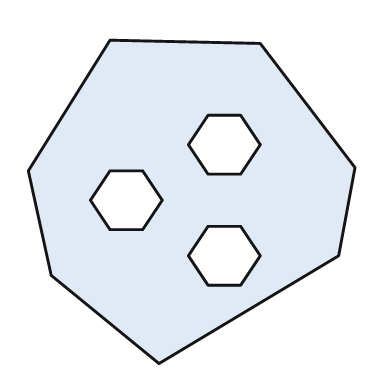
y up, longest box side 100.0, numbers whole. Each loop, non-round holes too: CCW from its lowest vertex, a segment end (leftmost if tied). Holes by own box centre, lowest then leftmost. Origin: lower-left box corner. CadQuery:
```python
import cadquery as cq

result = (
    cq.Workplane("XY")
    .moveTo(40.0, 0.0)
    .lineTo(95.0, 33.0)
    .lineTo(100.0, 60.0)
    .lineTo(71.0, 98.0)
    .lineTo(25.0, 99.0)
    .lineTo(0.0, 59.0)
    .lineTo(7.0, 27.0)
    .close()
    .moveTo(55.0, 24.0)
    .lineTo(65.0, 24.0)
    .lineTo(71.0, 33.0)
    .lineTo(65.0, 42.0)
    .lineTo(55.0, 42.0)
    .lineTo(49.0, 33.0)
    .close()
    .moveTo(25.0, 41.0)
    .lineTo(35.0, 41.0)
    .lineTo(41.0, 50.0)
    .lineTo(35.0, 59.0)
    .lineTo(25.0, 59.0)
    .lineTo(19.0, 50.0)
    .close()
    .moveTo(55.0, 58.0)
    .lineTo(65.0, 58.0)
    .lineTo(71.0, 67.0)
    .lineTo(65.0, 76.0)
    .lineTo(55.0, 76.0)
    .lineTo(49.0, 67.0)
    .close()
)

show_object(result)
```